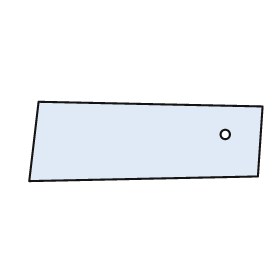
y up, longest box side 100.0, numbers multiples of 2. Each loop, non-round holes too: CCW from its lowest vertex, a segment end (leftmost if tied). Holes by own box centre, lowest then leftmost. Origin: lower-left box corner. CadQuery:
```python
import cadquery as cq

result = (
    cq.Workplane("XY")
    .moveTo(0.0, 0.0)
    .lineTo(98.0, 2.0)
    .lineTo(100.0, 32.0)
    .lineTo(4.0, 34.0)
    .close()
    .moveTo(84.0, 20.0)
    .circle(2.0)
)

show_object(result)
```